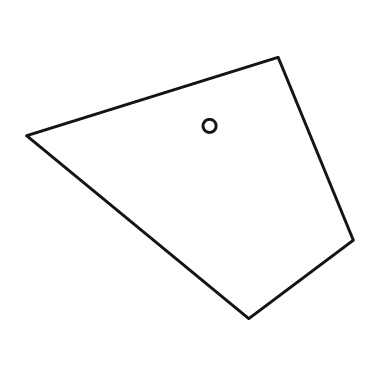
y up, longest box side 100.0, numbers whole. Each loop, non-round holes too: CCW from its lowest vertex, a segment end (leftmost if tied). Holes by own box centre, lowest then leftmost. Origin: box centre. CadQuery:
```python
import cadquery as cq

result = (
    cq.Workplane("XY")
    .moveTo(18.0, -40.0)
    .lineTo(50.0, -16.0)
    .lineTo(27.0, 40.0)
    .lineTo(-50.0, 16.0)
    .close()
    .moveTo(6.0, 19.0)
    .circle(2.0)
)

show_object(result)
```